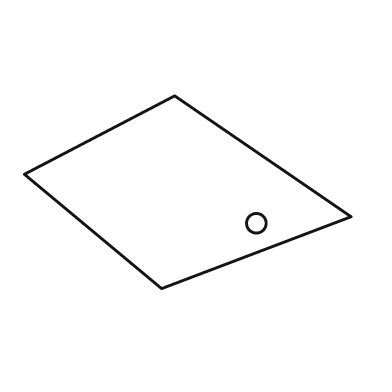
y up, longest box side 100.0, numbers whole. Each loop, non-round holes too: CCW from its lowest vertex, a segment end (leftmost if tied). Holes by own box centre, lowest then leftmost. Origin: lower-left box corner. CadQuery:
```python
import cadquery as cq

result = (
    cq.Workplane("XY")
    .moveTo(42.0, 0.0)
    .lineTo(100.0, 22.0)
    .lineTo(46.0, 59.0)
    .lineTo(0.0, 35.0)
    .close()
    .moveTo(71.0, 20.0)
    .circle(3.0)
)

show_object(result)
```